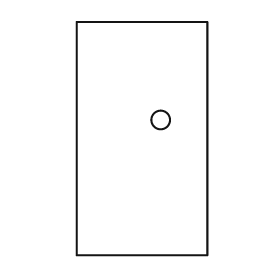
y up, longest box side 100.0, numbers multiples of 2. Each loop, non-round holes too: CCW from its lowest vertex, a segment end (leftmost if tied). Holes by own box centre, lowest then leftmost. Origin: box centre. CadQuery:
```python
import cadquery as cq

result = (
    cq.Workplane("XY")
    .moveTo(-28.0, -50.0)
    .lineTo(28.0, -50.0)
    .lineTo(28.0, 50.0)
    .lineTo(-28.0, 50.0)
    .close()
    .moveTo(8.0, 8.0)
    .circle(4.0)
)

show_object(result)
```